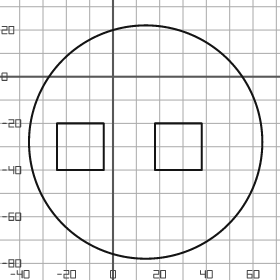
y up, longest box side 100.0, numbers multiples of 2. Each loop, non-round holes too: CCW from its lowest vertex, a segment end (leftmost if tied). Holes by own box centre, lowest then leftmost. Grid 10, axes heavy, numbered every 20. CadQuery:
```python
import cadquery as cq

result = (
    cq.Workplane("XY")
    .moveTo(14.0, -28.0)
    .circle(50.0)
    .moveTo(-24.0, -40.0)
    .lineTo(-4.0, -40.0)
    .lineTo(-4.0, -20.0)
    .lineTo(-24.0, -20.0)
    .close()
    .moveTo(18.0, -40.0)
    .lineTo(38.0, -40.0)
    .lineTo(38.0, -20.0)
    .lineTo(18.0, -20.0)
    .close()
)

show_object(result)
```